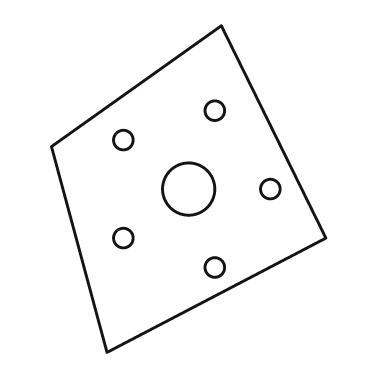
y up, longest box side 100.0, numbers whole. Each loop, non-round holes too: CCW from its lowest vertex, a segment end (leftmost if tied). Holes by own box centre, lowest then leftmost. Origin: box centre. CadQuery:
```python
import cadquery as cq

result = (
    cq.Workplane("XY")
    .moveTo(-25.0, -50.0)
    .lineTo(42.0, -15.0)
    .lineTo(10.0, 50.0)
    .lineTo(-42.0, 13.0)
    .close()
    .moveTo(8.0, -24.0)
    .circle(3.0)
    .moveTo(-20.0, -15.0)
    .circle(3.0)
    .moveTo(0.0, 0.0)
    .circle(8.0)
    .moveTo(25.0, 0.0)
    .circle(3.0)
    .moveTo(-20.0, 15.0)
    .circle(3.0)
    .moveTo(8.0, 24.0)
    .circle(3.0)
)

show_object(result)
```